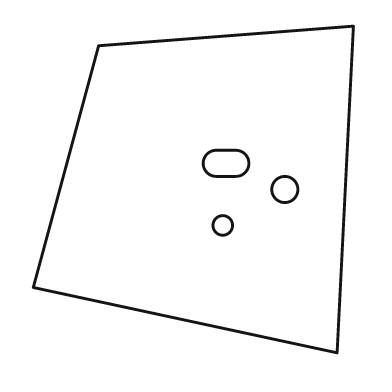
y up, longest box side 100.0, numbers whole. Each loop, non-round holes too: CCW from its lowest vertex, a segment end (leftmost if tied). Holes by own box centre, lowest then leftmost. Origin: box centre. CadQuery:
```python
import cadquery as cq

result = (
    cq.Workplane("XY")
    .moveTo(44.0, -50.0)
    .lineTo(49.0, 50.0)
    .lineTo(-29.0, 44.0)
    .lineTo(-49.0, -30.0)
    .close()
    .moveTo(9.0, -11.0)
    .circle(3.0)
    .moveTo(28.0, 0.0)
    .circle(4.0)
    .moveTo(7.0, 4.0)
    .lineTo(13.0, 4.0)
    .threePointArc((17.0, 8.0), (13.0, 12.0))
    .lineTo(7.0, 12.0)
    .threePointArc((3.0, 8.0), (7.0, 4.0))
    .close()
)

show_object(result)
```